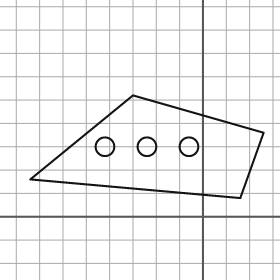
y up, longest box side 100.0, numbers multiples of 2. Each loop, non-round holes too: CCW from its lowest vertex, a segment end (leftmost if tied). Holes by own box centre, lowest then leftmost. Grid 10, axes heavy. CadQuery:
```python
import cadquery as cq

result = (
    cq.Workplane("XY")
    .moveTo(16.0, 8.0)
    .lineTo(26.0, 36.0)
    .lineTo(-30.0, 52.0)
    .lineTo(-74.0, 16.0)
    .close()
    .moveTo(-42.0, 30.0)
    .circle(4.0)
    .moveTo(-24.0, 30.0)
    .circle(4.0)
    .moveTo(-6.0, 30.0)
    .circle(4.0)
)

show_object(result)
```